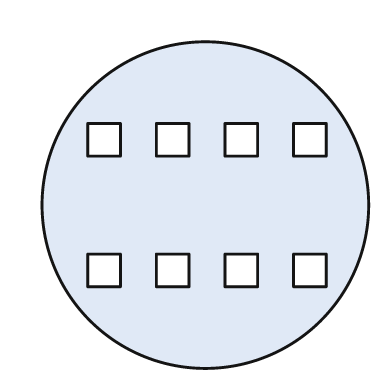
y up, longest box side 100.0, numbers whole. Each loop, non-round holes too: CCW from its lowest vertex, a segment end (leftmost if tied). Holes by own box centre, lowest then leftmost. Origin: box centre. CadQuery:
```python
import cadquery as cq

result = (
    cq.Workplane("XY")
    .moveTo(0.0, 0.0)
    .circle(50.0)
    .moveTo(-36.0, -25.0)
    .lineTo(-26.0, -25.0)
    .lineTo(-26.0, -15.0)
    .lineTo(-36.0, -15.0)
    .close()
    .moveTo(-15.0, -25.0)
    .lineTo(-5.0, -25.0)
    .lineTo(-5.0, -15.0)
    .lineTo(-15.0, -15.0)
    .close()
    .moveTo(6.0, -25.0)
    .lineTo(16.0, -25.0)
    .lineTo(16.0, -15.0)
    .lineTo(6.0, -15.0)
    .close()
    .moveTo(27.0, -25.0)
    .lineTo(37.0, -25.0)
    .lineTo(37.0, -15.0)
    .lineTo(27.0, -15.0)
    .close()
    .moveTo(-36.0, 15.0)
    .lineTo(-26.0, 15.0)
    .lineTo(-26.0, 25.0)
    .lineTo(-36.0, 25.0)
    .close()
    .moveTo(-15.0, 15.0)
    .lineTo(-5.0, 15.0)
    .lineTo(-5.0, 25.0)
    .lineTo(-15.0, 25.0)
    .close()
    .moveTo(6.0, 15.0)
    .lineTo(16.0, 15.0)
    .lineTo(16.0, 25.0)
    .lineTo(6.0, 25.0)
    .close()
    .moveTo(27.0, 15.0)
    .lineTo(37.0, 15.0)
    .lineTo(37.0, 25.0)
    .lineTo(27.0, 25.0)
    .close()
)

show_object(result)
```